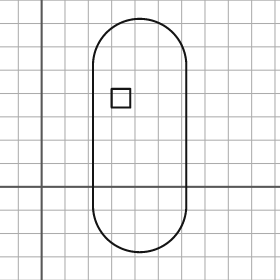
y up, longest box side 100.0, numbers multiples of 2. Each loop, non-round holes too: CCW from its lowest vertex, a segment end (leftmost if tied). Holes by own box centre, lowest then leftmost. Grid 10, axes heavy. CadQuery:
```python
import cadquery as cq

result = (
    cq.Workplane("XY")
    .moveTo(22.0, -8.0)
    .threePointArc((42.0, -28.0), (62.0, -8.0))
    .lineTo(62.0, 52.0)
    .threePointArc((42.0, 72.0), (22.0, 52.0))
    .close()
    .moveTo(30.0, 34.0)
    .lineTo(38.0, 34.0)
    .lineTo(38.0, 42.0)
    .lineTo(30.0, 42.0)
    .close()
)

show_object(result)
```